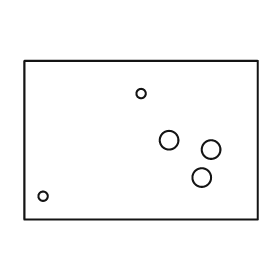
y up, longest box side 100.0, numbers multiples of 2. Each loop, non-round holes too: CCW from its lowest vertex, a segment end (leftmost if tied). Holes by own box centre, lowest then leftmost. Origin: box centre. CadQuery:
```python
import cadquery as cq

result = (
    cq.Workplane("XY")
    .moveTo(-50.0, -34.0)
    .lineTo(50.0, -34.0)
    .lineTo(50.0, 34.0)
    .lineTo(-50.0, 34.0)
    .close()
    .moveTo(-42.0, -24.0)
    .circle(2.0)
    .moveTo(26.0, -16.0)
    .circle(4.0)
    .moveTo(30.0, -4.0)
    .circle(4.0)
    .moveTo(12.0, 0.0)
    .circle(4.0)
    .moveTo(0.0, 20.0)
    .circle(2.0)
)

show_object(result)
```